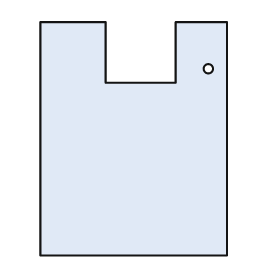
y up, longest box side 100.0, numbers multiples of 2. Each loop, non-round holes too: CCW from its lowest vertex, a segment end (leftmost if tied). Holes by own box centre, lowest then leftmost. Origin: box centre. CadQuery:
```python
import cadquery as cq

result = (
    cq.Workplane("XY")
    .moveTo(-40.0, -50.0)
    .lineTo(40.0, -50.0)
    .lineTo(40.0, 50.0)
    .lineTo(18.0, 50.0)
    .lineTo(18.0, 24.0)
    .lineTo(-12.0, 24.0)
    .lineTo(-12.0, 50.0)
    .lineTo(-40.0, 50.0)
    .close()
    .moveTo(32.0, 30.0)
    .circle(2.0)
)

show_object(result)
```